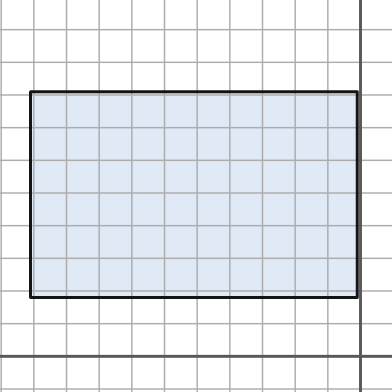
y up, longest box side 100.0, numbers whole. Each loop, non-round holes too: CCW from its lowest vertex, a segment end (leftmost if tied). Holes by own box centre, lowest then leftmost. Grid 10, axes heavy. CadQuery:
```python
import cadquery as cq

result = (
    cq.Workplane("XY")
    .moveTo(-101.0, 18.0)
    .lineTo(-1.0, 18.0)
    .lineTo(-1.0, 81.0)
    .lineTo(-101.0, 81.0)
    .close()
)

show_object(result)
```